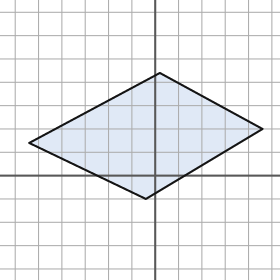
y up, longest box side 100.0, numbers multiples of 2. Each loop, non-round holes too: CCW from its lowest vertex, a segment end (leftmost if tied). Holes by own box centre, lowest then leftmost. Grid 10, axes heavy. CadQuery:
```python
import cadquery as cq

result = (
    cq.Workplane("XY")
    .moveTo(-4.0, -10.0)
    .lineTo(46.0, 20.0)
    .lineTo(2.0, 44.0)
    .lineTo(-54.0, 14.0)
    .close()
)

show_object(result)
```